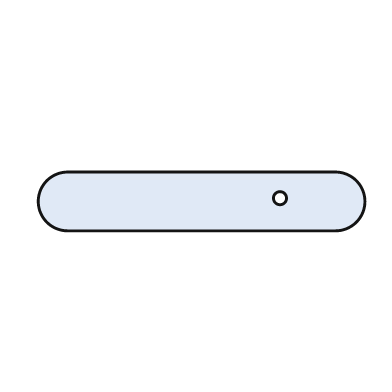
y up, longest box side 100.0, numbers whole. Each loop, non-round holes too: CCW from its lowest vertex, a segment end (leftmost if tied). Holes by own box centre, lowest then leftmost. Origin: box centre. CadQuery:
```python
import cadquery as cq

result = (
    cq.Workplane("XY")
    .moveTo(-41.0, -9.0)
    .lineTo(41.0, -9.0)
    .threePointArc((50.0, 0.0), (41.0, 9.0))
    .lineTo(-41.0, 9.0)
    .threePointArc((-50.0, 0.0), (-41.0, -9.0))
    .close()
    .moveTo(24.0, 1.0)
    .circle(2.0)
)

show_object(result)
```